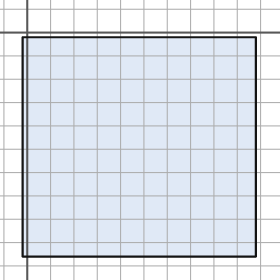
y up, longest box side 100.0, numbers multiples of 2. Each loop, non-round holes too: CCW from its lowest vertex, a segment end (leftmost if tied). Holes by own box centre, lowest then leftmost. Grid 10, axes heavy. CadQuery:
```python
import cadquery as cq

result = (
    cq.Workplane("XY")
    .moveTo(-2.0, -96.0)
    .lineTo(98.0, -96.0)
    .lineTo(98.0, -2.0)
    .lineTo(-2.0, -2.0)
    .close()
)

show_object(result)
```